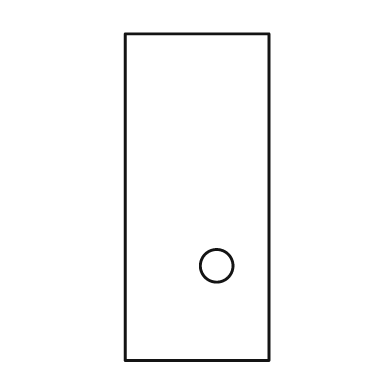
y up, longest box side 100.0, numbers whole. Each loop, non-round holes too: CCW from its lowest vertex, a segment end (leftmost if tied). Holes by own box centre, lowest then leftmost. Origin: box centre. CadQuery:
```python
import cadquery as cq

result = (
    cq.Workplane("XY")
    .moveTo(-22.0, -50.0)
    .lineTo(22.0, -50.0)
    .lineTo(22.0, 50.0)
    .lineTo(-22.0, 50.0)
    .close()
    .moveTo(6.0, -21.0)
    .circle(5.0)
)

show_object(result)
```